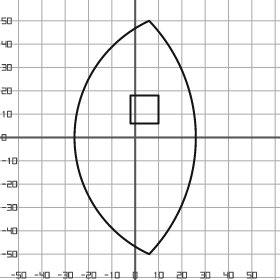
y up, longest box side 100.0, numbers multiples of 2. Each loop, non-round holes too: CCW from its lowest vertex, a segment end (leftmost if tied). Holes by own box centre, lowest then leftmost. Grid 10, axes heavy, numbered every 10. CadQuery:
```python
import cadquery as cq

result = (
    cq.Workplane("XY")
    .moveTo(6.0, -50.0)
    .threePointArc((26.0, 0.0), (6.0, 50.0))
    .threePointArc((-26.0, 0.0), (6.0, -50.0))
    .close()
    .moveTo(-2.0, 6.0)
    .lineTo(10.0, 6.0)
    .lineTo(10.0, 18.0)
    .lineTo(-2.0, 18.0)
    .close()
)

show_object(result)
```